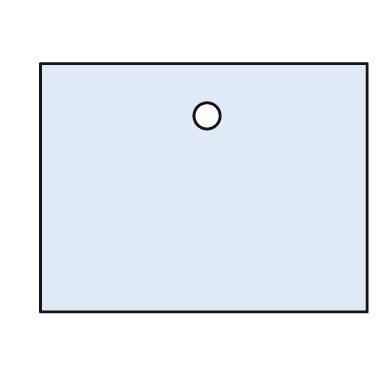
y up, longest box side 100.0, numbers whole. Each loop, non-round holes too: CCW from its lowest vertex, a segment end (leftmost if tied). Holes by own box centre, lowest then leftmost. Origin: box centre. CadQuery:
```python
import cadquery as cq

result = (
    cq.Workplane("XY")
    .moveTo(-50.0, -38.0)
    .lineTo(50.0, -38.0)
    .lineTo(50.0, 38.0)
    .lineTo(-50.0, 38.0)
    .close()
    .moveTo(1.0, 22.0)
    .circle(4.0)
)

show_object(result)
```